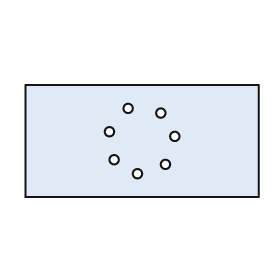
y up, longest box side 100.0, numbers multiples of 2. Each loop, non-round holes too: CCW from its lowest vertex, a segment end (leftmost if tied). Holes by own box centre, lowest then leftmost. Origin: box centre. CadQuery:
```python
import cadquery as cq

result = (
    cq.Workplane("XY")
    .moveTo(-50.0, -24.0)
    .lineTo(50.0, -24.0)
    .lineTo(50.0, 24.0)
    .lineTo(-50.0, 24.0)
    .close()
    .moveTo(-2.0, -14.0)
    .circle(2.0)
    .moveTo(10.0, -10.0)
    .circle(2.0)
    .moveTo(-12.0, -8.0)
    .circle(2.0)
    .moveTo(14.0, 2.0)
    .circle(2.0)
    .moveTo(-14.0, 4.0)
    .circle(2.0)
    .moveTo(8.0, 12.0)
    .circle(2.0)
    .moveTo(-6.0, 14.0)
    .circle(2.0)
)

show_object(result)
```